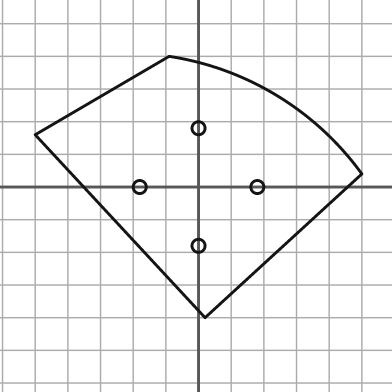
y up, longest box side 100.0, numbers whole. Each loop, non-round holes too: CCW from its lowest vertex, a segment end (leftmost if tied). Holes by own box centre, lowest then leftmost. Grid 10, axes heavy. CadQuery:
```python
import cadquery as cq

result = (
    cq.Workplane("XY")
    .moveTo(2.0, -40.0)
    .lineTo(50.0, 4.0)
    .threePointArc((24.0, 28.0), (-9.0, 40.0))
    .lineTo(-50.0, 16.0)
    .close()
    .moveTo(0.0, -18.0)
    .circle(2.0)
    .moveTo(-18.0, 0.0)
    .circle(2.0)
    .moveTo(18.0, 0.0)
    .circle(2.0)
    .moveTo(0.0, 18.0)
    .circle(2.0)
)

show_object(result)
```